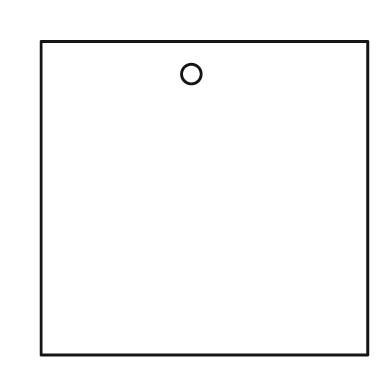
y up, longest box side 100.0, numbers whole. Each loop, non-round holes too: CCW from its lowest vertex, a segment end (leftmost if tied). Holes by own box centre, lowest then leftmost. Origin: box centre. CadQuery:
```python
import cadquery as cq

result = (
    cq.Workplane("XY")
    .moveTo(-50.0, -48.0)
    .lineTo(50.0, -48.0)
    .lineTo(50.0, 48.0)
    .lineTo(-50.0, 48.0)
    .close()
    .moveTo(-4.0, 38.0)
    .circle(3.0)
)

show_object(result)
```